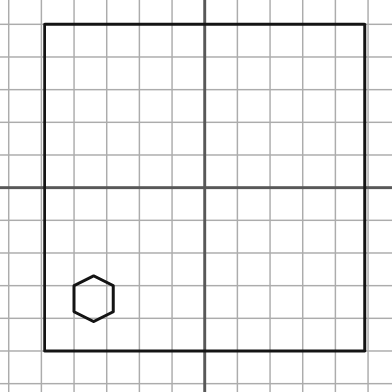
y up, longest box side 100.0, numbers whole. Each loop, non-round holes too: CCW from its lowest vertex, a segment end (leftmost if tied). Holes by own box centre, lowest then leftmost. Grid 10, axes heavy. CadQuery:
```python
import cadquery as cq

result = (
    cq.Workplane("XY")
    .moveTo(-49.0, -50.0)
    .lineTo(49.0, -50.0)
    .lineTo(49.0, 50.0)
    .lineTo(-49.0, 50.0)
    .close()
    .moveTo(-34.0, -41.0)
    .lineTo(-28.0, -38.0)
    .lineTo(-28.0, -30.0)
    .lineTo(-34.0, -27.0)
    .lineTo(-40.0, -30.0)
    .lineTo(-40.0, -38.0)
    .close()
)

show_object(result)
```